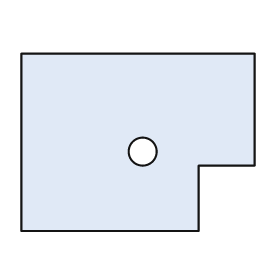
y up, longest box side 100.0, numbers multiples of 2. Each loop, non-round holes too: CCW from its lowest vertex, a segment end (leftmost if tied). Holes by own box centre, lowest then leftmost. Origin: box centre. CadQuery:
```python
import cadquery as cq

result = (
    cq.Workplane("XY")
    .moveTo(-50.0, -38.0)
    .lineTo(26.0, -38.0)
    .lineTo(26.0, -10.0)
    .lineTo(50.0, -10.0)
    .lineTo(50.0, 38.0)
    .lineTo(-50.0, 38.0)
    .close()
    .moveTo(2.0, -4.0)
    .circle(6.0)
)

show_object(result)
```